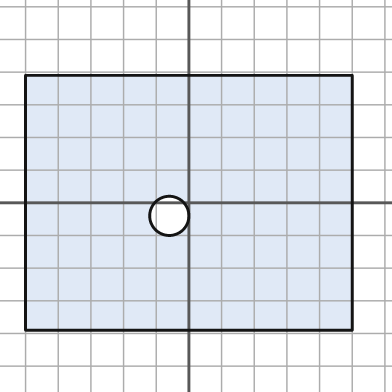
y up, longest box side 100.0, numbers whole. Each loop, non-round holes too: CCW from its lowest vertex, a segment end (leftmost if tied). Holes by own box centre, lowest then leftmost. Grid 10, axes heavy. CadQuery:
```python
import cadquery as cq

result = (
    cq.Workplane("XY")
    .moveTo(-50.0, -39.0)
    .lineTo(50.0, -39.0)
    .lineTo(50.0, 39.0)
    .lineTo(-50.0, 39.0)
    .close()
    .moveTo(-6.0, -4.0)
    .circle(6.0)
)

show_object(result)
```